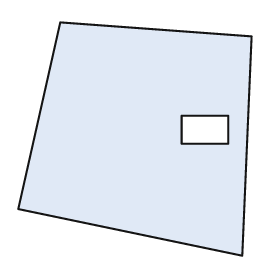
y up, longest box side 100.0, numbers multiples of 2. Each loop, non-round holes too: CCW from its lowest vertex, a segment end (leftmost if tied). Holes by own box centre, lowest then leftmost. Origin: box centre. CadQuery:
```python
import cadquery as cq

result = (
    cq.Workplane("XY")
    .moveTo(46.0, -50.0)
    .lineTo(50.0, 44.0)
    .lineTo(-32.0, 50.0)
    .lineTo(-50.0, -30.0)
    .close()
    .moveTo(20.0, -2.0)
    .lineTo(40.0, -2.0)
    .lineTo(40.0, 10.0)
    .lineTo(20.0, 10.0)
    .close()
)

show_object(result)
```